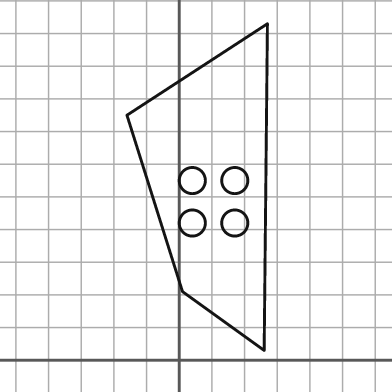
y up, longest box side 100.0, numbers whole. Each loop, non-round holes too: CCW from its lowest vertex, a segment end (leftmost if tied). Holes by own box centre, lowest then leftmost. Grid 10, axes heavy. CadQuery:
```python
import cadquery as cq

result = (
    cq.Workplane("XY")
    .moveTo(26.0, 3.0)
    .lineTo(27.0, 103.0)
    .lineTo(-16.0, 75.0)
    .lineTo(1.0, 21.0)
    .close()
    .moveTo(4.0, 42.0)
    .circle(4.0)
    .moveTo(17.0, 42.0)
    .circle(4.0)
    .moveTo(4.0, 55.0)
    .circle(4.0)
    .moveTo(17.0, 55.0)
    .circle(4.0)
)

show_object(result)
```